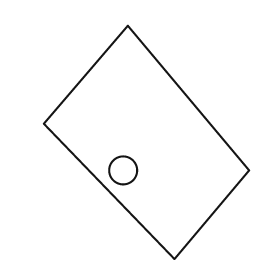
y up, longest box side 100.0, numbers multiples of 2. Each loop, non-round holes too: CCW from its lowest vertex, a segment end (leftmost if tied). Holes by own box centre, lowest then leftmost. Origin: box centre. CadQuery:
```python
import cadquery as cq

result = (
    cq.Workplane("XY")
    .moveTo(12.0, -50.0)
    .lineTo(44.0, -12.0)
    .lineTo(-8.0, 50.0)
    .lineTo(-44.0, 8.0)
    .close()
    .moveTo(-10.0, -12.0)
    .circle(6.0)
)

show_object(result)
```